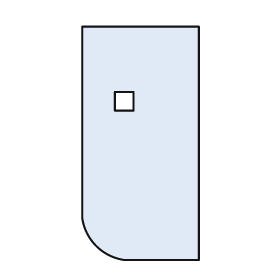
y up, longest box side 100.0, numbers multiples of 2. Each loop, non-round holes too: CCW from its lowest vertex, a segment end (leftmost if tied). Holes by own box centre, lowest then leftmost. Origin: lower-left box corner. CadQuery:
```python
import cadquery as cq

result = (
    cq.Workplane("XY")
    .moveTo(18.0, 0.0)
    .lineTo(50.0, 0.0)
    .lineTo(50.0, 100.0)
    .lineTo(0.0, 100.0)
    .lineTo(0.0, 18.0)
    .threePointArc((6.0, 6.0), (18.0, 0.0))
    .close()
    .moveTo(14.0, 64.0)
    .lineTo(22.0, 64.0)
    .lineTo(22.0, 72.0)
    .lineTo(14.0, 72.0)
    .close()
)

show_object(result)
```